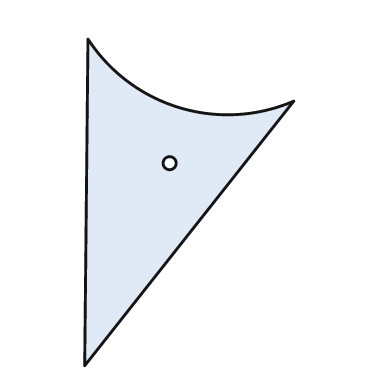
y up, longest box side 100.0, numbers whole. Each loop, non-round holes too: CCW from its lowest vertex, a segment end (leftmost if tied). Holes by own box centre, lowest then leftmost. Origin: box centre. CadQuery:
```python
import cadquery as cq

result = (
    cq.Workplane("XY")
    .moveTo(-32.0, -50.0)
    .lineTo(32.0, 31.0)
    .threePointArc((-3.0, 29.0), (-31.0, 50.0))
    .close()
    .moveTo(-6.0, 12.0)
    .circle(2.0)
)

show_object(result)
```